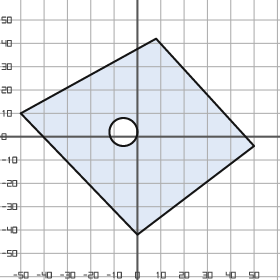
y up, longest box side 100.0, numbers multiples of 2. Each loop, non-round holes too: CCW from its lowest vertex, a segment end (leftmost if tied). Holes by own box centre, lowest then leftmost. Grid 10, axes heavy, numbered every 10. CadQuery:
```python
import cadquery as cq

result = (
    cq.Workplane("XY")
    .moveTo(0.0, -42.0)
    .lineTo(50.0, -4.0)
    .lineTo(8.0, 42.0)
    .lineTo(-50.0, 10.0)
    .close()
    .moveTo(-6.0, 2.0)
    .circle(6.0)
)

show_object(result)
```